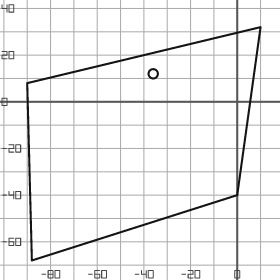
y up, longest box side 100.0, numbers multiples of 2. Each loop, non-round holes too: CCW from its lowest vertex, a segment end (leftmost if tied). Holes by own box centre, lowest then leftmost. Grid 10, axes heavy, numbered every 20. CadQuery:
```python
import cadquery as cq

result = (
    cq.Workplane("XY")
    .moveTo(-88.0, -68.0)
    .lineTo(0.0, -40.0)
    .lineTo(10.0, 32.0)
    .lineTo(-90.0, 8.0)
    .close()
    .moveTo(-36.0, 12.0)
    .circle(2.0)
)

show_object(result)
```